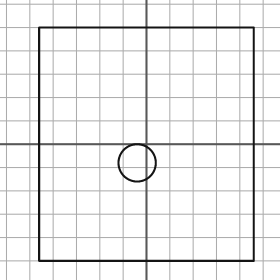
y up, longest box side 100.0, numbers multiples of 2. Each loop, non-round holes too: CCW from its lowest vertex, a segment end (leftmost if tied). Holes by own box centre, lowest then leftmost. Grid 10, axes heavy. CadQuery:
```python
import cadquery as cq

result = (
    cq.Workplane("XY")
    .moveTo(-46.0, -50.0)
    .lineTo(46.0, -50.0)
    .lineTo(46.0, 50.0)
    .lineTo(-46.0, 50.0)
    .close()
    .moveTo(-4.0, -8.0)
    .circle(8.0)
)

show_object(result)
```